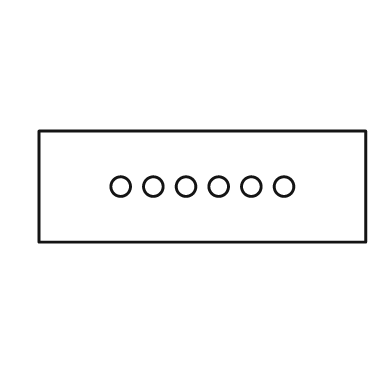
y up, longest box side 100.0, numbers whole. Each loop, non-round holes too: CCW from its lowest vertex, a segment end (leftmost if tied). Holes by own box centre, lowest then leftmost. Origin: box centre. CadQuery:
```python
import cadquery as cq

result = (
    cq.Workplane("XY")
    .moveTo(-50.0, -17.0)
    .lineTo(50.0, -17.0)
    .lineTo(50.0, 17.0)
    .lineTo(-50.0, 17.0)
    .close()
    .moveTo(-25.0, 0.0)
    .circle(3.0)
    .moveTo(-15.0, 0.0)
    .circle(3.0)
    .moveTo(-5.0, 0.0)
    .circle(3.0)
    .moveTo(5.0, 0.0)
    .circle(3.0)
    .moveTo(15.0, 0.0)
    .circle(3.0)
    .moveTo(25.0, 0.0)
    .circle(3.0)
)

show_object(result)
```